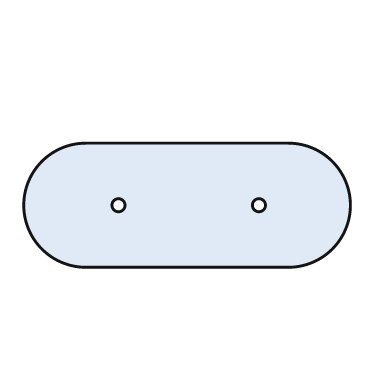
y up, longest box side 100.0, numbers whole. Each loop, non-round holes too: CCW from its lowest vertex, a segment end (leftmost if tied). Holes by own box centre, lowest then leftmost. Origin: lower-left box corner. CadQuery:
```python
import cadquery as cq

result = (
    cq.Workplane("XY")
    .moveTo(19.0, 0.0)
    .lineTo(81.0, 0.0)
    .threePointArc((100.0, 19.0), (81.0, 38.0))
    .lineTo(19.0, 38.0)
    .threePointArc((0.0, 19.0), (19.0, 0.0))
    .close()
    .moveTo(29.0, 19.0)
    .circle(2.0)
    .moveTo(72.0, 19.0)
    .circle(2.0)
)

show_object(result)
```